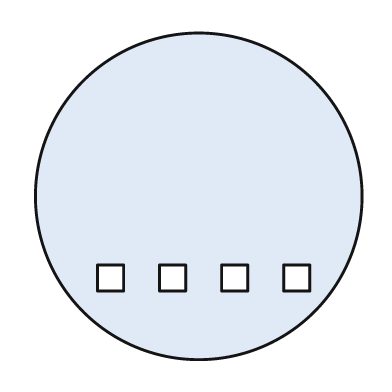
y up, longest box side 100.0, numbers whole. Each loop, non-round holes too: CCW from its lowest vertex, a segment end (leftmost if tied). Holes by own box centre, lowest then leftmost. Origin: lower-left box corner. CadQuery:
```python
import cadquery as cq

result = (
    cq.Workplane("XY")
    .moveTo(50.0, 50.0)
    .circle(50.0)
    .moveTo(19.0, 21.0)
    .lineTo(27.0, 21.0)
    .lineTo(27.0, 29.0)
    .lineTo(19.0, 29.0)
    .close()
    .moveTo(38.0, 21.0)
    .lineTo(46.0, 21.0)
    .lineTo(46.0, 29.0)
    .lineTo(38.0, 29.0)
    .close()
    .moveTo(57.0, 21.0)
    .lineTo(65.0, 21.0)
    .lineTo(65.0, 29.0)
    .lineTo(57.0, 29.0)
    .close()
    .moveTo(76.0, 21.0)
    .lineTo(84.0, 21.0)
    .lineTo(84.0, 29.0)
    .lineTo(76.0, 29.0)
    .close()
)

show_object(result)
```